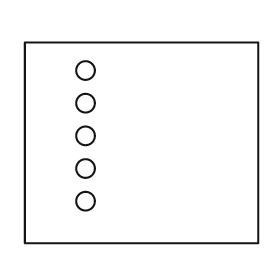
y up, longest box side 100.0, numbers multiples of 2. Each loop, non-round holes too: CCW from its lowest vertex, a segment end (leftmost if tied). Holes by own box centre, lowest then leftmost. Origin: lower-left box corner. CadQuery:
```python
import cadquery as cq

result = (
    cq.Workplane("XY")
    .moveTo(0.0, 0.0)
    .lineTo(100.0, 0.0)
    .lineTo(100.0, 86.0)
    .lineTo(0.0, 86.0)
    .close()
    .moveTo(26.0, 18.0)
    .circle(4.0)
    .moveTo(26.0, 32.0)
    .circle(4.0)
    .moveTo(26.0, 46.0)
    .circle(4.0)
    .moveTo(26.0, 60.0)
    .circle(4.0)
    .moveTo(26.0, 74.0)
    .circle(4.0)
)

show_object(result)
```